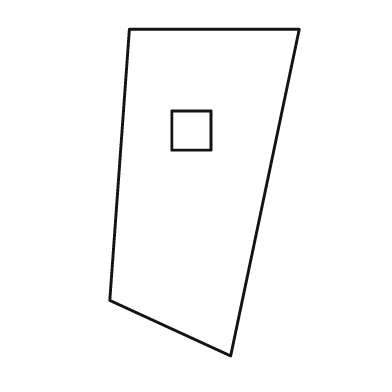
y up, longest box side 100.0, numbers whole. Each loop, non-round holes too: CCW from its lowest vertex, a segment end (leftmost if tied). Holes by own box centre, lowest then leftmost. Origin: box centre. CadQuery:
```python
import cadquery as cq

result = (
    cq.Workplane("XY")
    .moveTo(8.0, -50.0)
    .lineTo(29.0, 50.0)
    .lineTo(-23.0, 50.0)
    .lineTo(-29.0, -33.0)
    .close()
    .moveTo(-10.0, 13.0)
    .lineTo(2.0, 13.0)
    .lineTo(2.0, 25.0)
    .lineTo(-10.0, 25.0)
    .close()
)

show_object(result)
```